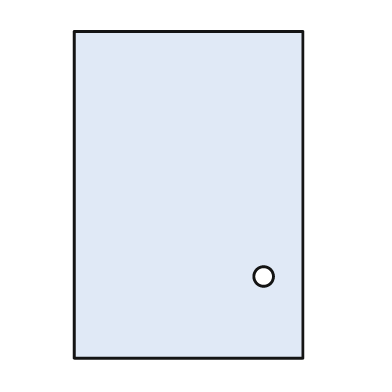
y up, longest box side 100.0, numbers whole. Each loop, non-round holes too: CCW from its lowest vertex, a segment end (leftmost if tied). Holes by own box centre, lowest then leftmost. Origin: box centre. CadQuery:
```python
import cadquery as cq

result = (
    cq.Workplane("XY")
    .moveTo(-35.0, -50.0)
    .lineTo(35.0, -50.0)
    .lineTo(35.0, 50.0)
    .lineTo(-35.0, 50.0)
    .close()
    .moveTo(23.0, -25.0)
    .circle(3.0)
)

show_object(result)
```